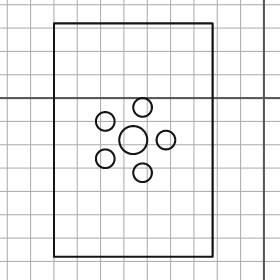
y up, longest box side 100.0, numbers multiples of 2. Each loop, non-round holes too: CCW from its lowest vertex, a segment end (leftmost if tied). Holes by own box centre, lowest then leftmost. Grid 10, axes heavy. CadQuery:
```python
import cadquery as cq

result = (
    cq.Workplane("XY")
    .moveTo(-90.0, -68.0)
    .lineTo(-22.0, -68.0)
    .lineTo(-22.0, 32.0)
    .lineTo(-90.0, 32.0)
    .close()
    .moveTo(-52.0, -32.0)
    .circle(4.0)
    .moveTo(-68.0, -26.0)
    .circle(4.0)
    .moveTo(-56.0, -18.0)
    .circle(6.0)
    .moveTo(-42.0, -18.0)
    .circle(4.0)
    .moveTo(-68.0, -10.0)
    .circle(4.0)
    .moveTo(-52.0, -4.0)
    .circle(4.0)
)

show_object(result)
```